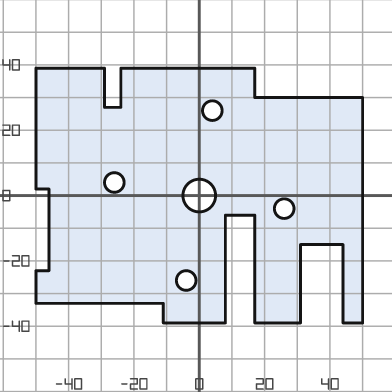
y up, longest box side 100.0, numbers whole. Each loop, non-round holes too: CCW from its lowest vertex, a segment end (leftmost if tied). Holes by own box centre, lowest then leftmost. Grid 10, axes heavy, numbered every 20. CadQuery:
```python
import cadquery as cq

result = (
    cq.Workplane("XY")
    .moveTo(-11.0, -39.0)
    .lineTo(8.0, -39.0)
    .lineTo(8.0, -6.0)
    .lineTo(17.0, -6.0)
    .lineTo(17.0, -39.0)
    .lineTo(31.0, -39.0)
    .lineTo(31.0, -15.0)
    .lineTo(44.0, -15.0)
    .lineTo(44.0, -39.0)
    .lineTo(50.0, -39.0)
    .lineTo(50.0, 30.0)
    .lineTo(17.0, 30.0)
    .lineTo(17.0, 39.0)
    .lineTo(-24.0, 39.0)
    .lineTo(-24.0, 27.0)
    .lineTo(-29.0, 27.0)
    .lineTo(-29.0, 39.0)
    .lineTo(-50.0, 39.0)
    .lineTo(-50.0, 2.0)
    .lineTo(-46.0, 2.0)
    .lineTo(-46.0, -23.0)
    .lineTo(-50.0, -23.0)
    .lineTo(-50.0, -33.0)
    .lineTo(-11.0, -33.0)
    .close()
    .moveTo(-4.0, -26.0)
    .circle(3.0)
    .moveTo(26.0, -4.0)
    .circle(3.0)
    .moveTo(0.0, 0.0)
    .circle(5.0)
    .moveTo(-26.0, 4.0)
    .circle(3.0)
    .moveTo(4.0, 26.0)
    .circle(3.0)
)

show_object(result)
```